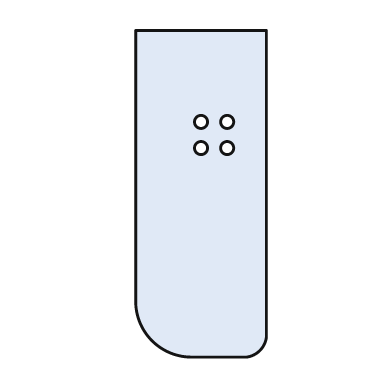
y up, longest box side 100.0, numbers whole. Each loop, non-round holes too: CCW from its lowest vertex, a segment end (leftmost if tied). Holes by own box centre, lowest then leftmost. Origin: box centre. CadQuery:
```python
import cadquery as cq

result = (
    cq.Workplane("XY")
    .moveTo(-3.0, -50.0)
    .lineTo(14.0, -50.0)
    .threePointArc((18.0, -48.0), (20.0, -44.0))
    .lineTo(20.0, 50.0)
    .lineTo(-20.0, 50.0)
    .lineTo(-20.0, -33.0)
    .threePointArc((-15.0, -45.0), (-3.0, -50.0))
    .close()
    .moveTo(0.0, 14.0)
    .circle(2.0)
    .moveTo(8.0, 14.0)
    .circle(2.0)
    .moveTo(0.0, 22.0)
    .circle(2.0)
    .moveTo(8.0, 22.0)
    .circle(2.0)
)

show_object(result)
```